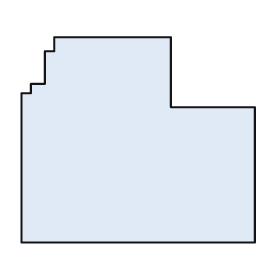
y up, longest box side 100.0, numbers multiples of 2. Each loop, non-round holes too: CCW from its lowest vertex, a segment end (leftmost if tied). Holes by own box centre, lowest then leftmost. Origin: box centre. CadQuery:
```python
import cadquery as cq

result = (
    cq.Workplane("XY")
    .moveTo(-50.0, -44.0)
    .lineTo(50.0, -44.0)
    .lineTo(50.0, 14.0)
    .lineTo(14.0, 14.0)
    .lineTo(14.0, 44.0)
    .lineTo(-36.0, 44.0)
    .lineTo(-36.0, 38.0)
    .lineTo(-40.0, 38.0)
    .lineTo(-40.0, 24.0)
    .lineTo(-46.0, 24.0)
    .lineTo(-46.0, 20.0)
    .lineTo(-50.0, 20.0)
    .close()
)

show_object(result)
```